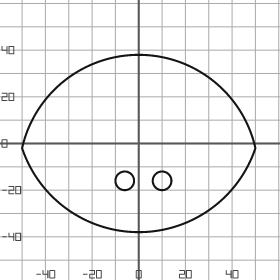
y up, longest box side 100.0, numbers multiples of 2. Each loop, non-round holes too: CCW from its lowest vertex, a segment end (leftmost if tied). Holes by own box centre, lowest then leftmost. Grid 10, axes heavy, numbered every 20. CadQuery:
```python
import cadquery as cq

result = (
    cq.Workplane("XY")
    .moveTo(-50.0, -2.0)
    .threePointArc((0.0, -38.0), (50.0, -2.0))
    .threePointArc((0.0, 38.0), (-50.0, -2.0))
    .close()
    .moveTo(-6.0, -16.0)
    .circle(4.0)
    .moveTo(10.0, -16.0)
    .circle(4.0)
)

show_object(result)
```